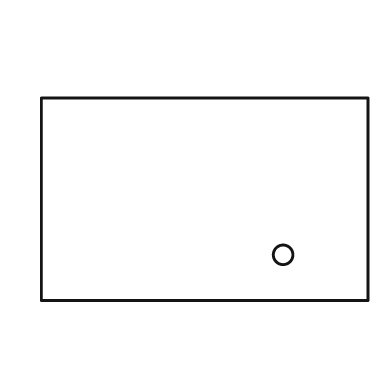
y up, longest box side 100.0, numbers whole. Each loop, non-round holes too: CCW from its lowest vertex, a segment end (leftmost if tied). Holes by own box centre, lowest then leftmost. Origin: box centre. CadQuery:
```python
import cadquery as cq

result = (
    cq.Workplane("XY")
    .moveTo(-50.0, -31.0)
    .lineTo(50.0, -31.0)
    .lineTo(50.0, 31.0)
    .lineTo(-50.0, 31.0)
    .close()
    .moveTo(24.0, -17.0)
    .circle(3.0)
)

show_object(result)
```